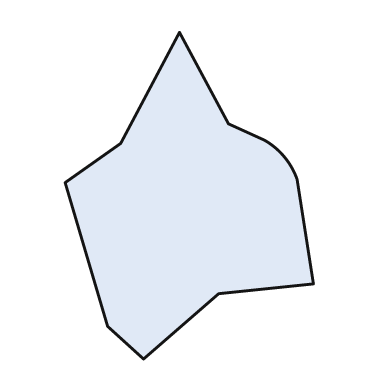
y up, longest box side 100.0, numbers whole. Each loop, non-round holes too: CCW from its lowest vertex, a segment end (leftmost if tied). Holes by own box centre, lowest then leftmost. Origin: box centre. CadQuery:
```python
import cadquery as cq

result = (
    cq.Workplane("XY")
    .moveTo(-14.0, -50.0)
    .lineTo(9.0, -30.0)
    .lineTo(38.0, -27.0)
    .lineTo(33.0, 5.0)
    .threePointArc((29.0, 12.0), (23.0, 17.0))
    .lineTo(12.0, 22.0)
    .lineTo(-3.0, 50.0)
    .lineTo(-21.0, 16.0)
    .lineTo(-38.0, 4.0)
    .lineTo(-25.0, -40.0)
    .close()
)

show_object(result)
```